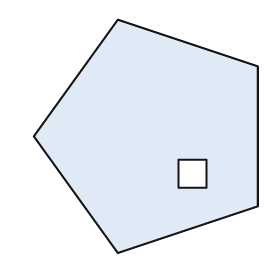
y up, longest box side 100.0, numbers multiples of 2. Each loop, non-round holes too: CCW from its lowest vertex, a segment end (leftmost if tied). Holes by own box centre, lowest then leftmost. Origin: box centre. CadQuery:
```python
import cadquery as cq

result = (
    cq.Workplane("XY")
    .moveTo(-12.0, -50.0)
    .lineTo(48.0, -30.0)
    .lineTo(48.0, 30.0)
    .lineTo(-12.0, 50.0)
    .lineTo(-48.0, 0.0)
    .close()
    .moveTo(14.0, -22.0)
    .lineTo(26.0, -22.0)
    .lineTo(26.0, -10.0)
    .lineTo(14.0, -10.0)
    .close()
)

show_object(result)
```